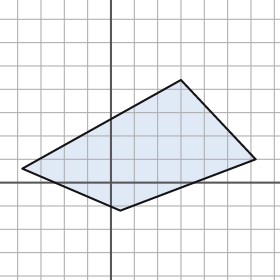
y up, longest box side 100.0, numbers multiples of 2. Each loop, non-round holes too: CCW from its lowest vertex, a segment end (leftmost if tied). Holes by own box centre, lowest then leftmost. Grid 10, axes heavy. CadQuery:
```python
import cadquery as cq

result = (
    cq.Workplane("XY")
    .moveTo(4.0, -12.0)
    .lineTo(62.0, 10.0)
    .lineTo(30.0, 44.0)
    .lineTo(-38.0, 6.0)
    .close()
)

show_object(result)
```